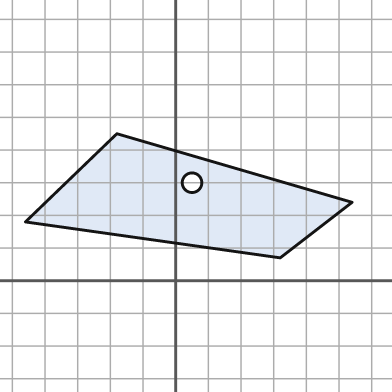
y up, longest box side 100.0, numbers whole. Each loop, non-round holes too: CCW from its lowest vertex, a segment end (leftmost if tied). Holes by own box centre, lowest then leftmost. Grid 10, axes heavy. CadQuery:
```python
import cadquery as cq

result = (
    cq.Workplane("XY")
    .moveTo(32.0, 7.0)
    .lineTo(54.0, 24.0)
    .lineTo(-18.0, 45.0)
    .lineTo(-46.0, 18.0)
    .close()
    .moveTo(5.0, 30.0)
    .circle(3.0)
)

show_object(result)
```